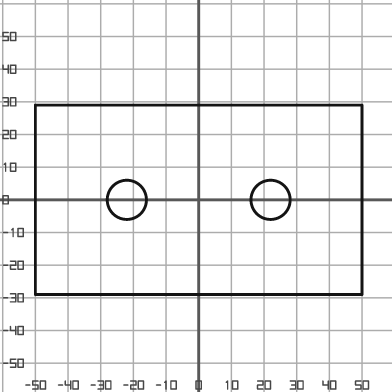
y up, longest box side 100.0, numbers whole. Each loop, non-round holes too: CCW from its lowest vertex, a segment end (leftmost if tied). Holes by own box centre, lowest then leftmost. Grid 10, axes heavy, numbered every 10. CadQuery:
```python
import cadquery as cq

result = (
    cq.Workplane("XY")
    .moveTo(-50.0, -29.0)
    .lineTo(50.0, -29.0)
    .lineTo(50.0, 29.0)
    .lineTo(-50.0, 29.0)
    .close()
    .moveTo(-22.0, 0.0)
    .circle(6.0)
    .moveTo(22.0, 0.0)
    .circle(6.0)
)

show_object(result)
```